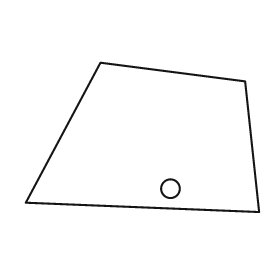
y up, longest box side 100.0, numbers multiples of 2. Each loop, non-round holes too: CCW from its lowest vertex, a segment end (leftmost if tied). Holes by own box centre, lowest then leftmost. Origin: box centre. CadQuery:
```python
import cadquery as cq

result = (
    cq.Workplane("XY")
    .moveTo(50.0, -32.0)
    .lineTo(44.0, 24.0)
    .lineTo(-18.0, 32.0)
    .lineTo(-50.0, -28.0)
    .close()
    .moveTo(12.0, -22.0)
    .circle(4.0)
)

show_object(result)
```